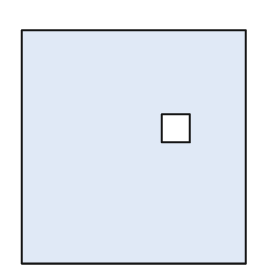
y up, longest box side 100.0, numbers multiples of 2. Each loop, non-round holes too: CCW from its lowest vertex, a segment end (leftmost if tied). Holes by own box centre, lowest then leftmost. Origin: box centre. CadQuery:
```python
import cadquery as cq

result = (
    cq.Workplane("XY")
    .moveTo(-48.0, -50.0)
    .lineTo(48.0, -50.0)
    .lineTo(48.0, 50.0)
    .lineTo(-48.0, 50.0)
    .close()
    .moveTo(12.0, 2.0)
    .lineTo(24.0, 2.0)
    .lineTo(24.0, 14.0)
    .lineTo(12.0, 14.0)
    .close()
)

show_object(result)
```